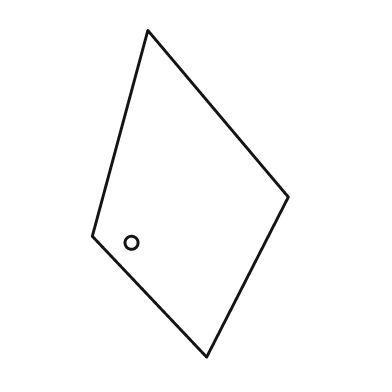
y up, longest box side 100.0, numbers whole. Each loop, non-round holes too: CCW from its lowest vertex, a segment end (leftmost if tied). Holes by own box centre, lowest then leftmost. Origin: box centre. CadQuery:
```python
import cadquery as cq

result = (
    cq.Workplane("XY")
    .moveTo(5.0, -50.0)
    .lineTo(30.0, -1.0)
    .lineTo(-13.0, 50.0)
    .lineTo(-30.0, -13.0)
    .close()
    .moveTo(-18.0, -15.0)
    .circle(2.0)
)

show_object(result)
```